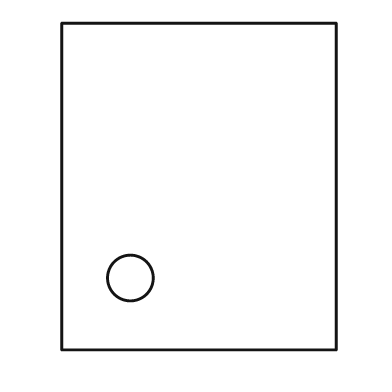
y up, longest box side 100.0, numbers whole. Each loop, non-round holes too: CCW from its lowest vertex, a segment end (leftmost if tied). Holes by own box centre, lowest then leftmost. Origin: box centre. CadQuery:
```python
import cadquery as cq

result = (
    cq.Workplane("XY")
    .moveTo(-42.0, -50.0)
    .lineTo(42.0, -50.0)
    .lineTo(42.0, 50.0)
    .lineTo(-42.0, 50.0)
    .close()
    .moveTo(-21.0, -28.0)
    .circle(7.0)
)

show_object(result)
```